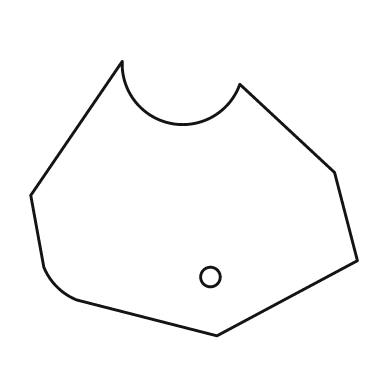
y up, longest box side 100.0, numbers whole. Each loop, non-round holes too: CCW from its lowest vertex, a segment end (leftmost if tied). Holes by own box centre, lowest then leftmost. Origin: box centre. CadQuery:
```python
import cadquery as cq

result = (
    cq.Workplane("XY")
    .moveTo(7.0, -42.0)
    .lineTo(50.0, -19.0)
    .lineTo(43.0, 8.0)
    .lineTo(14.0, 35.0)
    .threePointArc((-7.0, 23.0), (-22.0, 42.0))
    .lineTo(-50.0, 1.0)
    .lineTo(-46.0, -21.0)
    .threePointArc((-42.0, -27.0), (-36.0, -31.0))
    .close()
    .moveTo(5.0, -24.0)
    .circle(3.0)
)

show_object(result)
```